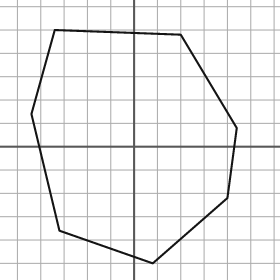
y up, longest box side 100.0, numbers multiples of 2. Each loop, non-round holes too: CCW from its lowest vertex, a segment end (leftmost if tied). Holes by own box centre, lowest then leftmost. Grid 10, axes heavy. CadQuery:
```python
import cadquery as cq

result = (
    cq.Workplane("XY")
    .moveTo(8.0, -50.0)
    .lineTo(40.0, -22.0)
    .lineTo(44.0, 8.0)
    .lineTo(20.0, 48.0)
    .lineTo(-34.0, 50.0)
    .lineTo(-44.0, 14.0)
    .lineTo(-32.0, -36.0)
    .close()
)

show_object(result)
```